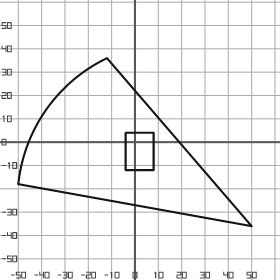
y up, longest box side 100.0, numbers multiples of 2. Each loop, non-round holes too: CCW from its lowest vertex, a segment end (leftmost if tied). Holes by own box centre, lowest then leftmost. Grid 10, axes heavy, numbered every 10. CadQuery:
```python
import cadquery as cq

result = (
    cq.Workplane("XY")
    .moveTo(50.0, -36.0)
    .lineTo(-12.0, 36.0)
    .threePointArc((-38.0, 14.0), (-50.0, -18.0))
    .close()
    .moveTo(-4.0, -12.0)
    .lineTo(8.0, -12.0)
    .lineTo(8.0, 4.0)
    .lineTo(-4.0, 4.0)
    .close()
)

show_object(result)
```